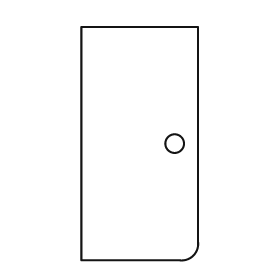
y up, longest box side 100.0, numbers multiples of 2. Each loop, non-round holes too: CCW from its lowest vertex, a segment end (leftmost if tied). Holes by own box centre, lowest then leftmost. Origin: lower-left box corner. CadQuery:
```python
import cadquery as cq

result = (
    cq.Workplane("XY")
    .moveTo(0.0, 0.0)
    .lineTo(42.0, 0.0)
    .threePointArc((48.0, 2.0), (50.0, 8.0))
    .lineTo(50.0, 100.0)
    .lineTo(0.0, 100.0)
    .close()
    .moveTo(40.0, 50.0)
    .circle(4.0)
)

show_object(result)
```